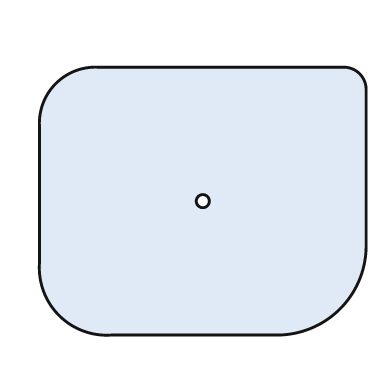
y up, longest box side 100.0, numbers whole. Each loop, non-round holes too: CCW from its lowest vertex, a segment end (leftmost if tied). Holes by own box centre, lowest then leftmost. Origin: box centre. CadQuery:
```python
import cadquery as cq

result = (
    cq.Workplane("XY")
    .moveTo(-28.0, -41.0)
    .lineTo(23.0, -41.0)
    .threePointArc((42.0, -33.0), (50.0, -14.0))
    .lineTo(50.0, 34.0)
    .threePointArc((48.0, 39.0), (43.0, 41.0))
    .lineTo(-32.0, 41.0)
    .threePointArc((-45.0, 36.0), (-50.0, 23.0))
    .lineTo(-50.0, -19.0)
    .threePointArc((-44.0, -35.0), (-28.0, -41.0))
    .close()
    .moveTo(0.0, 0.0)
    .circle(2.0)
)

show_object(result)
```